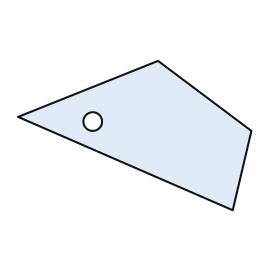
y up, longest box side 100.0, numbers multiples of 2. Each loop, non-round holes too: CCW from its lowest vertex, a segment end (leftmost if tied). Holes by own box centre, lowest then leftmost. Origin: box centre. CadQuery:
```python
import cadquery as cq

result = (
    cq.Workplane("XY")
    .moveTo(42.0, -32.0)
    .lineTo(50.0, 2.0)
    .lineTo(10.0, 32.0)
    .lineTo(-50.0, 8.0)
    .close()
    .moveTo(-18.0, 6.0)
    .circle(4.0)
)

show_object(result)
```